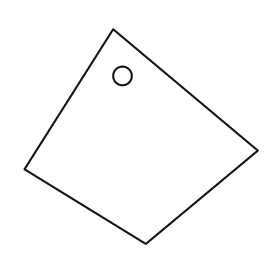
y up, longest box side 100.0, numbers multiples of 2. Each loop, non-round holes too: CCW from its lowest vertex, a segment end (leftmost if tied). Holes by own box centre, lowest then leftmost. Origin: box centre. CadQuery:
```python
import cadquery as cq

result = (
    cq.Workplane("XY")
    .moveTo(2.0, -46.0)
    .lineTo(50.0, -6.0)
    .lineTo(-12.0, 46.0)
    .lineTo(-50.0, -14.0)
    .close()
    .moveTo(-8.0, 26.0)
    .circle(4.0)
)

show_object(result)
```